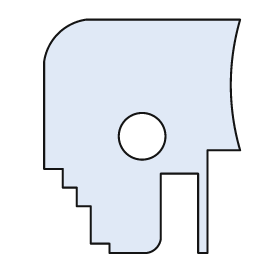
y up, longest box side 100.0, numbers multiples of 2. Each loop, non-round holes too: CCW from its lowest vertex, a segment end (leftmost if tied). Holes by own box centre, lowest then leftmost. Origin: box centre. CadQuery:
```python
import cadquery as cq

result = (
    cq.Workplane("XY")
    .moveTo(-14.0, -50.0)
    .lineTo(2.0, -50.0)
    .threePointArc((6.0, -48.0), (8.0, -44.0))
    .lineTo(8.0, -16.0)
    .lineTo(24.0, -16.0)
    .lineTo(24.0, -50.0)
    .lineTo(28.0, -50.0)
    .lineTo(28.0, -6.0)
    .lineTo(42.0, -6.0)
    .threePointArc((38.0, 22.0), (42.0, 50.0))
    .lineTo(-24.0, 50.0)
    .threePointArc((-36.0, 44.0), (-42.0, 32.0))
    .lineTo(-42.0, -14.0)
    .lineTo(-34.0, -14.0)
    .lineTo(-34.0, -22.0)
    .lineTo(-28.0, -22.0)
    .lineTo(-28.0, -30.0)
    .lineTo(-22.0, -30.0)
    .lineTo(-22.0, -46.0)
    .lineTo(-14.0, -46.0)
    .close()
    .moveTo(0.0, 0.0)
    .circle(10.0)
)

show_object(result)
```